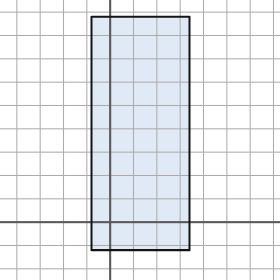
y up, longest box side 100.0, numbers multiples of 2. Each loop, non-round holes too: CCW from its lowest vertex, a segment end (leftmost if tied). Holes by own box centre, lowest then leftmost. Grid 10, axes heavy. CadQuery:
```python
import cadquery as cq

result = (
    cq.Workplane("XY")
    .moveTo(-8.0, -12.0)
    .lineTo(34.0, -12.0)
    .lineTo(34.0, 88.0)
    .lineTo(-8.0, 88.0)
    .close()
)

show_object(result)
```